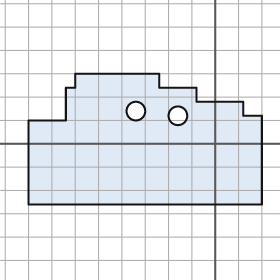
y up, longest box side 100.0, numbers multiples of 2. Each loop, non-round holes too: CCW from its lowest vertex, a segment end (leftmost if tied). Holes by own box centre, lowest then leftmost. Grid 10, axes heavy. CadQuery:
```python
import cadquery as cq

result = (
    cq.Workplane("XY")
    .moveTo(-80.0, -26.0)
    .lineTo(20.0, -26.0)
    .lineTo(20.0, 12.0)
    .lineTo(12.0, 12.0)
    .lineTo(12.0, 18.0)
    .lineTo(-8.0, 18.0)
    .lineTo(-8.0, 24.0)
    .lineTo(-24.0, 24.0)
    .lineTo(-24.0, 30.0)
    .lineTo(-60.0, 30.0)
    .lineTo(-60.0, 24.0)
    .lineTo(-64.0, 24.0)
    .lineTo(-64.0, 10.0)
    .lineTo(-80.0, 10.0)
    .close()
    .moveTo(-16.0, 12.0)
    .circle(4.0)
    .moveTo(-34.0, 14.0)
    .circle(4.0)
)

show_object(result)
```